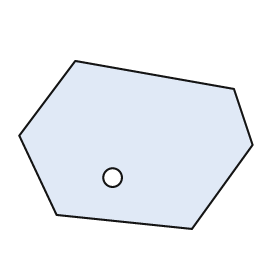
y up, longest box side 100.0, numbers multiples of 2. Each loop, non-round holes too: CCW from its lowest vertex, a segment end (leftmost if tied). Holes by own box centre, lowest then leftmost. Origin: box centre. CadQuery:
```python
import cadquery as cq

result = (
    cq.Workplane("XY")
    .moveTo(24.0, -36.0)
    .lineTo(50.0, 0.0)
    .lineTo(42.0, 24.0)
    .lineTo(-26.0, 36.0)
    .lineTo(-50.0, 4.0)
    .lineTo(-34.0, -30.0)
    .close()
    .moveTo(-10.0, -14.0)
    .circle(4.0)
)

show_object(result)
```